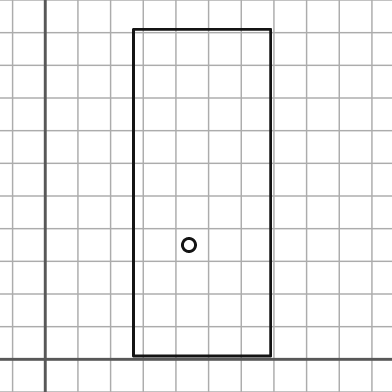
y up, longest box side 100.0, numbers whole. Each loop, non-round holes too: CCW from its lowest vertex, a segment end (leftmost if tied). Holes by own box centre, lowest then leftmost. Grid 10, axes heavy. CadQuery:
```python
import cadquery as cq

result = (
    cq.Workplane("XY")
    .moveTo(27.0, 1.0)
    .lineTo(69.0, 1.0)
    .lineTo(69.0, 101.0)
    .lineTo(27.0, 101.0)
    .close()
    .moveTo(44.0, 35.0)
    .circle(2.0)
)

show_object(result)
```